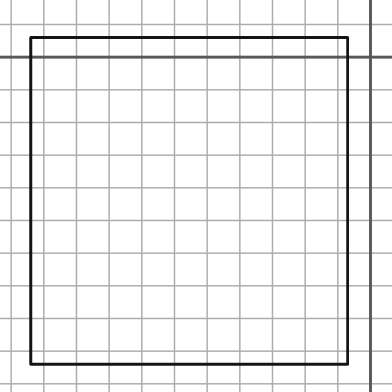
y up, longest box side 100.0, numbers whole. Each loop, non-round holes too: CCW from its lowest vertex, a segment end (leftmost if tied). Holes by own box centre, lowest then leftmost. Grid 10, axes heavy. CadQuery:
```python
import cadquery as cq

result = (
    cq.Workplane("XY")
    .moveTo(-104.0, -94.0)
    .lineTo(-7.0, -94.0)
    .lineTo(-7.0, 6.0)
    .lineTo(-104.0, 6.0)
    .close()
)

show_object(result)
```